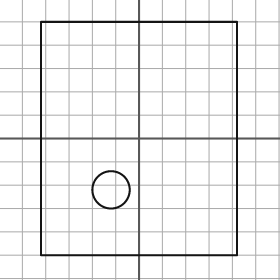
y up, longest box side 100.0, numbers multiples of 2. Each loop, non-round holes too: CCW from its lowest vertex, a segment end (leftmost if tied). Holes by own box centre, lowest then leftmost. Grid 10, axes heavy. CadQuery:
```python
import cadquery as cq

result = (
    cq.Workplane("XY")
    .moveTo(-42.0, -50.0)
    .lineTo(42.0, -50.0)
    .lineTo(42.0, 50.0)
    .lineTo(-42.0, 50.0)
    .close()
    .moveTo(-12.0, -22.0)
    .circle(8.0)
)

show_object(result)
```